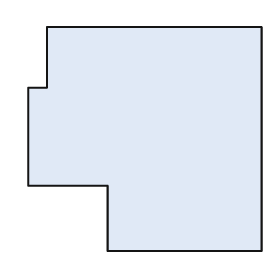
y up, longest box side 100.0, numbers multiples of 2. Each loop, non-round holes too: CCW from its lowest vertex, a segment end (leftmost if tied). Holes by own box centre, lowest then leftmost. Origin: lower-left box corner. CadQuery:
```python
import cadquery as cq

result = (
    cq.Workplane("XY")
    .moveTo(34.0, 0.0)
    .lineTo(100.0, 0.0)
    .lineTo(100.0, 96.0)
    .lineTo(8.0, 96.0)
    .lineTo(8.0, 70.0)
    .lineTo(0.0, 70.0)
    .lineTo(0.0, 28.0)
    .lineTo(34.0, 28.0)
    .close()
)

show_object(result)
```